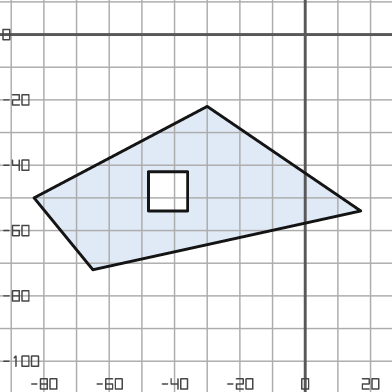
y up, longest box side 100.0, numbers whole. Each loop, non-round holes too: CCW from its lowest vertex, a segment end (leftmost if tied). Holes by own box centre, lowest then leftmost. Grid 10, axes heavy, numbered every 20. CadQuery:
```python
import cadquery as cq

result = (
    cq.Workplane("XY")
    .moveTo(-65.0, -72.0)
    .lineTo(17.0, -54.0)
    .lineTo(-30.0, -22.0)
    .lineTo(-83.0, -50.0)
    .close()
    .moveTo(-48.0, -54.0)
    .lineTo(-36.0, -54.0)
    .lineTo(-36.0, -42.0)
    .lineTo(-48.0, -42.0)
    .close()
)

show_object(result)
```